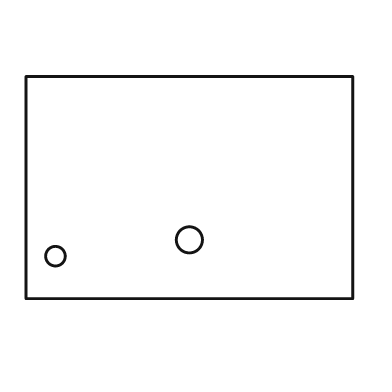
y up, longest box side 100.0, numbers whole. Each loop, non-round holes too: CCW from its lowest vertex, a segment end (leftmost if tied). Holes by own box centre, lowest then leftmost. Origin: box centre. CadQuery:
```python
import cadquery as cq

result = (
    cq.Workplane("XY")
    .moveTo(-50.0, -34.0)
    .lineTo(50.0, -34.0)
    .lineTo(50.0, 34.0)
    .lineTo(-50.0, 34.0)
    .close()
    .moveTo(-41.0, -21.0)
    .circle(3.0)
    .moveTo(0.0, -16.0)
    .circle(4.0)
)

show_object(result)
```